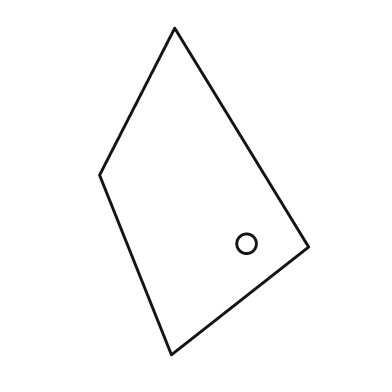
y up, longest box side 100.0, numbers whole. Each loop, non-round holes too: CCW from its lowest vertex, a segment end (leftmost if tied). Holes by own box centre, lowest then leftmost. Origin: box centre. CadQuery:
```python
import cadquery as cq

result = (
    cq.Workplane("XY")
    .moveTo(-10.0, -50.0)
    .lineTo(32.0, -17.0)
    .lineTo(-9.0, 50.0)
    .lineTo(-32.0, 5.0)
    .close()
    .moveTo(13.0, -16.0)
    .circle(3.0)
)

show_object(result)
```